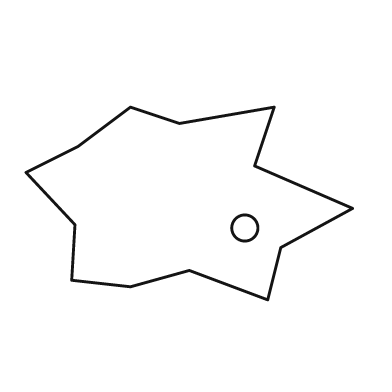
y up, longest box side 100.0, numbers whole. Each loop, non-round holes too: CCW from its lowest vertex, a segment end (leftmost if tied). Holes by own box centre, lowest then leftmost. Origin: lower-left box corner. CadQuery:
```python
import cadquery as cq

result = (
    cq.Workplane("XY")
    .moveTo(74.0, 0.0)
    .lineTo(78.0, 16.0)
    .lineTo(100.0, 28.0)
    .lineTo(70.0, 41.0)
    .lineTo(76.0, 59.0)
    .lineTo(47.0, 54.0)
    .lineTo(32.0, 59.0)
    .lineTo(16.0, 47.0)
    .lineTo(0.0, 39.0)
    .lineTo(15.0, 23.0)
    .lineTo(14.0, 6.0)
    .lineTo(32.0, 4.0)
    .lineTo(50.0, 9.0)
    .close()
    .moveTo(67.0, 22.0)
    .circle(4.0)
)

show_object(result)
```